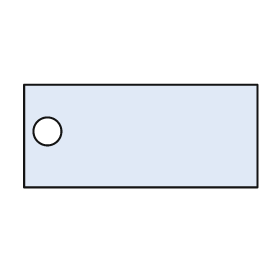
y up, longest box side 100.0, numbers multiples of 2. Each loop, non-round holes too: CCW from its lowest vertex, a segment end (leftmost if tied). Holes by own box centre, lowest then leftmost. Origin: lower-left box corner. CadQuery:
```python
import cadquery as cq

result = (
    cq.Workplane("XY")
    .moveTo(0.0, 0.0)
    .lineTo(100.0, 0.0)
    .lineTo(100.0, 44.0)
    .lineTo(0.0, 44.0)
    .close()
    .moveTo(10.0, 24.0)
    .circle(6.0)
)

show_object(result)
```